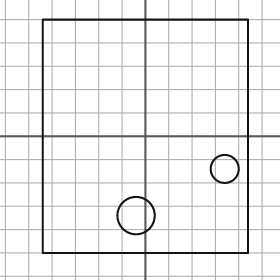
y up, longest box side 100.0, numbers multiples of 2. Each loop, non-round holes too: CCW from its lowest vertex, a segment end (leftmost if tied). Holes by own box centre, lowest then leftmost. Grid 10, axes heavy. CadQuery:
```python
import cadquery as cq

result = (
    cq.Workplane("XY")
    .moveTo(-44.0, -50.0)
    .lineTo(44.0, -50.0)
    .lineTo(44.0, 50.0)
    .lineTo(-44.0, 50.0)
    .close()
    .moveTo(-4.0, -34.0)
    .circle(8.0)
    .moveTo(34.0, -14.0)
    .circle(6.0)
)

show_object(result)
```